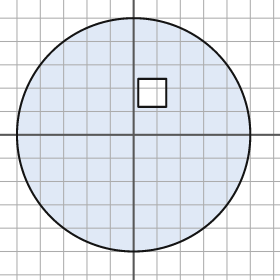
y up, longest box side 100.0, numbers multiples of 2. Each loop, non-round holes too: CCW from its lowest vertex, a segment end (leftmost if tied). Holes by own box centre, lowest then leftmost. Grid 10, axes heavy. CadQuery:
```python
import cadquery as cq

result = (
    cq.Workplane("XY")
    .moveTo(0.0, 0.0)
    .circle(50.0)
    .moveTo(2.0, 12.0)
    .lineTo(14.0, 12.0)
    .lineTo(14.0, 24.0)
    .lineTo(2.0, 24.0)
    .close()
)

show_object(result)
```